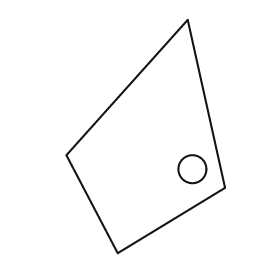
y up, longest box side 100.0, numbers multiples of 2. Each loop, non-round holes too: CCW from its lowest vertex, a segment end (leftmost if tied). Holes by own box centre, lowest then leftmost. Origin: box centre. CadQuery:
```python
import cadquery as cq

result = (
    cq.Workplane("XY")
    .moveTo(-12.0, -50.0)
    .lineTo(34.0, -22.0)
    .lineTo(18.0, 50.0)
    .lineTo(-34.0, -8.0)
    .close()
    .moveTo(20.0, -14.0)
    .circle(6.0)
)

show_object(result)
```